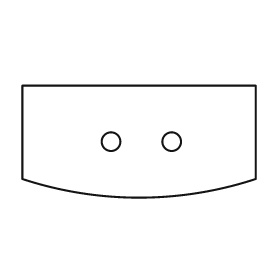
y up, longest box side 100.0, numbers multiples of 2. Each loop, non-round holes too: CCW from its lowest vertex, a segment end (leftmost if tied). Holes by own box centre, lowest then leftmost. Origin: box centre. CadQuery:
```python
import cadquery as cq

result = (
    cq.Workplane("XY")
    .moveTo(-50.0, -16.0)
    .threePointArc((0.0, -24.0), (50.0, -16.0))
    .lineTo(50.0, 24.0)
    .lineTo(-50.0, 24.0)
    .close()
    .moveTo(-12.0, 0.0)
    .circle(4.0)
    .moveTo(14.0, 0.0)
    .circle(4.0)
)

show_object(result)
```